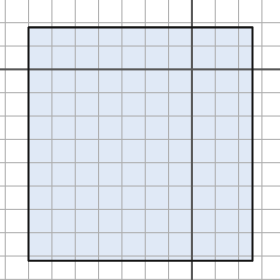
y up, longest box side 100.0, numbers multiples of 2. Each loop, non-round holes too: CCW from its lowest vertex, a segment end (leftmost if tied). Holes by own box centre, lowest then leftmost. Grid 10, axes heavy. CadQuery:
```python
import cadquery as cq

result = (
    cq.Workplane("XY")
    .moveTo(-70.0, -82.0)
    .lineTo(26.0, -82.0)
    .lineTo(26.0, 18.0)
    .lineTo(-70.0, 18.0)
    .close()
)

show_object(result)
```